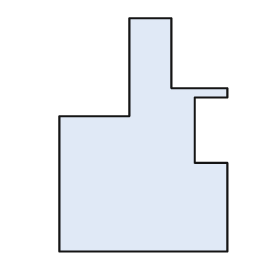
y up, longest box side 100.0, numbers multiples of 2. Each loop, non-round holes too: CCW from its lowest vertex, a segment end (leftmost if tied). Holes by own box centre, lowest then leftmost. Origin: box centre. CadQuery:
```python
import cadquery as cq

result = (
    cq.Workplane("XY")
    .moveTo(-36.0, -50.0)
    .lineTo(36.0, -50.0)
    .lineTo(36.0, -12.0)
    .lineTo(22.0, -12.0)
    .lineTo(22.0, 16.0)
    .lineTo(36.0, 16.0)
    .lineTo(36.0, 20.0)
    .lineTo(12.0, 20.0)
    .lineTo(12.0, 50.0)
    .lineTo(-6.0, 50.0)
    .lineTo(-6.0, 8.0)
    .lineTo(-36.0, 8.0)
    .close()
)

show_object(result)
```